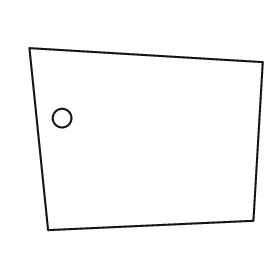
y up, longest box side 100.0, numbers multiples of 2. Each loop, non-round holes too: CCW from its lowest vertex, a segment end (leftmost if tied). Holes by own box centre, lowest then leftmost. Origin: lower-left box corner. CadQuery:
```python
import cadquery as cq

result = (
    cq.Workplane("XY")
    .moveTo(8.0, 0.0)
    .lineTo(96.0, 4.0)
    .lineTo(100.0, 72.0)
    .lineTo(0.0, 78.0)
    .close()
    .moveTo(14.0, 48.0)
    .circle(4.0)
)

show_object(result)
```